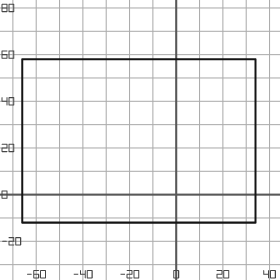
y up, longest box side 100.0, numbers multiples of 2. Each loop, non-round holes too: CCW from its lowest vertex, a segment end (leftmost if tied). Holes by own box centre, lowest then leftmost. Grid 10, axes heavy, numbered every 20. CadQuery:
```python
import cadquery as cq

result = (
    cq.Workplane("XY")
    .moveTo(-66.0, -12.0)
    .lineTo(34.0, -12.0)
    .lineTo(34.0, 58.0)
    .lineTo(-66.0, 58.0)
    .close()
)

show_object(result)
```